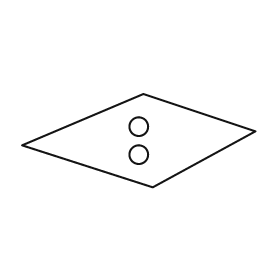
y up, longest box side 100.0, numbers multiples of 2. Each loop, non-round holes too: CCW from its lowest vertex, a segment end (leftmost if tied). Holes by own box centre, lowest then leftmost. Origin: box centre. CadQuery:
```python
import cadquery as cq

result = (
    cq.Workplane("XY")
    .moveTo(6.0, -20.0)
    .lineTo(50.0, 4.0)
    .lineTo(2.0, 20.0)
    .lineTo(-50.0, -2.0)
    .close()
    .moveTo(0.0, -6.0)
    .circle(4.0)
    .moveTo(0.0, 6.0)
    .circle(4.0)
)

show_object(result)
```